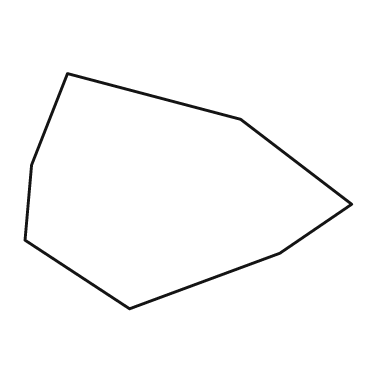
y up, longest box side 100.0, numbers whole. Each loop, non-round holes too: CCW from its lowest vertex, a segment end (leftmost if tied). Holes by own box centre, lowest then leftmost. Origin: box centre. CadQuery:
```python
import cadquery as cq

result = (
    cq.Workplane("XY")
    .moveTo(-18.0, -36.0)
    .lineTo(28.0, -19.0)
    .lineTo(50.0, -4.0)
    .lineTo(16.0, 22.0)
    .lineTo(-37.0, 36.0)
    .lineTo(-48.0, 8.0)
    .lineTo(-50.0, -15.0)
    .close()
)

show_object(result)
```